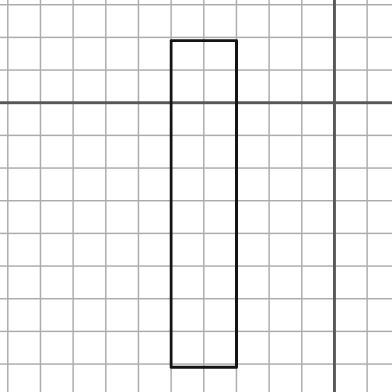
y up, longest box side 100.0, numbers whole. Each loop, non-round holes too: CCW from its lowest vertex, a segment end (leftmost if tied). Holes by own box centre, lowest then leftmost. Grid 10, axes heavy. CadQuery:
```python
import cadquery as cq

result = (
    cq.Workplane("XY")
    .moveTo(-50.0, -81.0)
    .lineTo(-30.0, -81.0)
    .lineTo(-30.0, 19.0)
    .lineTo(-50.0, 19.0)
    .close()
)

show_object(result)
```